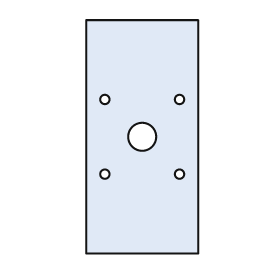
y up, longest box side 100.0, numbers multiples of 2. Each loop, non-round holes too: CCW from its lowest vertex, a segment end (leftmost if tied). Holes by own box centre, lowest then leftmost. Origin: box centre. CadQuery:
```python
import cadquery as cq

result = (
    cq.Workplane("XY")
    .moveTo(-24.0, -50.0)
    .lineTo(24.0, -50.0)
    .lineTo(24.0, 50.0)
    .lineTo(-24.0, 50.0)
    .close()
    .moveTo(-16.0, -16.0)
    .circle(2.0)
    .moveTo(16.0, -16.0)
    .circle(2.0)
    .moveTo(0.0, 0.0)
    .circle(6.0)
    .moveTo(-16.0, 16.0)
    .circle(2.0)
    .moveTo(16.0, 16.0)
    .circle(2.0)
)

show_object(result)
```